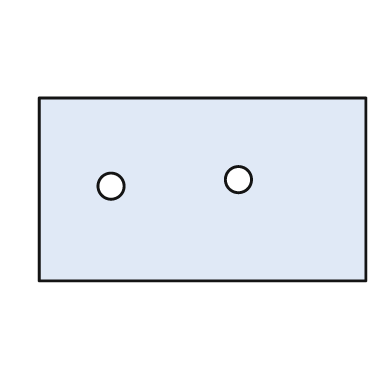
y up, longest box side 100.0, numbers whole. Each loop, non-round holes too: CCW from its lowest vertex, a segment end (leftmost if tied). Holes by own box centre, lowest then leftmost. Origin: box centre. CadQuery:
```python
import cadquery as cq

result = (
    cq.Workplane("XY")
    .moveTo(-50.0, -28.0)
    .lineTo(50.0, -28.0)
    .lineTo(50.0, 28.0)
    .lineTo(-50.0, 28.0)
    .close()
    .moveTo(-28.0, 1.0)
    .circle(4.0)
    .moveTo(11.0, 3.0)
    .circle(4.0)
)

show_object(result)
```